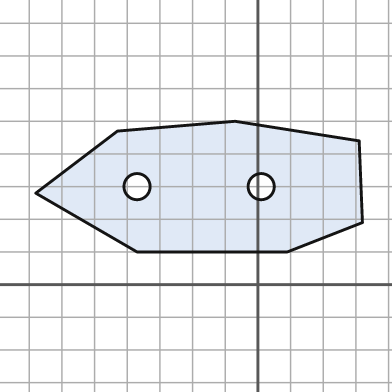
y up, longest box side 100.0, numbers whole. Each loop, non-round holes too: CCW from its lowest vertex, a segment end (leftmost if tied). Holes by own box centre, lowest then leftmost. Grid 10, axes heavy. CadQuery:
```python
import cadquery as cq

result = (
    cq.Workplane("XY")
    .moveTo(-37.0, 10.0)
    .lineTo(9.0, 10.0)
    .lineTo(32.0, 19.0)
    .lineTo(31.0, 44.0)
    .lineTo(-7.0, 50.0)
    .lineTo(-43.0, 47.0)
    .lineTo(-68.0, 28.0)
    .close()
    .moveTo(-37.0, 30.0)
    .circle(4.0)
    .moveTo(1.0, 30.0)
    .circle(4.0)
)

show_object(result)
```